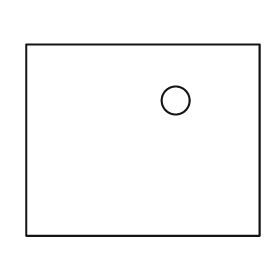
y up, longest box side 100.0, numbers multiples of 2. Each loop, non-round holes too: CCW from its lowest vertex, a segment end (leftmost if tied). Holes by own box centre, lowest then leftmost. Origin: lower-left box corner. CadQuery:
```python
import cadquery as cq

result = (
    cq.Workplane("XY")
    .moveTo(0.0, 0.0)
    .lineTo(100.0, 0.0)
    .lineTo(100.0, 82.0)
    .lineTo(0.0, 82.0)
    .close()
    .moveTo(64.0, 58.0)
    .circle(6.0)
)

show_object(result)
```